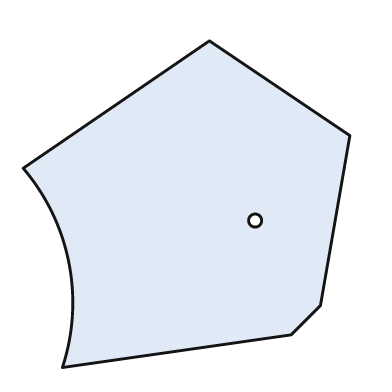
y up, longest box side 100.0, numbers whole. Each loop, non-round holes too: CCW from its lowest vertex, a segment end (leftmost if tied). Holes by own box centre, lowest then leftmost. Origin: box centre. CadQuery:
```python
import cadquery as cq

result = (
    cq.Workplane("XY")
    .moveTo(-38.0, -50.0)
    .lineTo(32.0, -40.0)
    .lineTo(41.0, -31.0)
    .lineTo(50.0, 21.0)
    .lineTo(7.0, 50.0)
    .lineTo(-50.0, 11.0)
    .threePointArc((-36.0, -18.0), (-38.0, -50.0))
    .close()
    .moveTo(21.0, -5.0)
    .circle(2.0)
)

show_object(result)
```